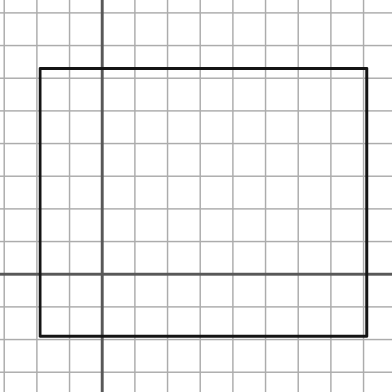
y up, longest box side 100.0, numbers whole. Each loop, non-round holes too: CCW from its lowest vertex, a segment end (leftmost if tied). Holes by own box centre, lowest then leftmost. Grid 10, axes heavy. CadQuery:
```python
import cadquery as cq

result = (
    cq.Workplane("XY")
    .moveTo(-19.0, -19.0)
    .lineTo(81.0, -19.0)
    .lineTo(81.0, 63.0)
    .lineTo(-19.0, 63.0)
    .close()
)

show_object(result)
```